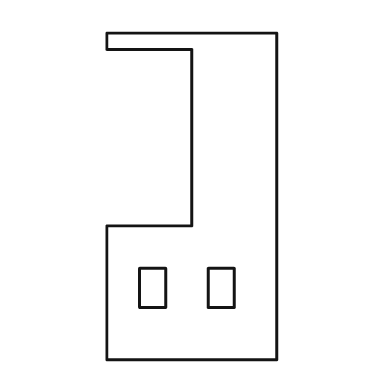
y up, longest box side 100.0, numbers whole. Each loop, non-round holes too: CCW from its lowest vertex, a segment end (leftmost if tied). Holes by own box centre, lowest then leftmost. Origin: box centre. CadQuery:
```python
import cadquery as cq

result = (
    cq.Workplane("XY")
    .moveTo(-26.0, -50.0)
    .lineTo(26.0, -50.0)
    .lineTo(26.0, 50.0)
    .lineTo(-26.0, 50.0)
    .lineTo(-26.0, 45.0)
    .lineTo(0.0, 45.0)
    .lineTo(0.0, -9.0)
    .lineTo(-26.0, -9.0)
    .close()
    .moveTo(-16.0, -34.0)
    .lineTo(-8.0, -34.0)
    .lineTo(-8.0, -22.0)
    .lineTo(-16.0, -22.0)
    .close()
    .moveTo(5.0, -34.0)
    .lineTo(13.0, -34.0)
    .lineTo(13.0, -22.0)
    .lineTo(5.0, -22.0)
    .close()
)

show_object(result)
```